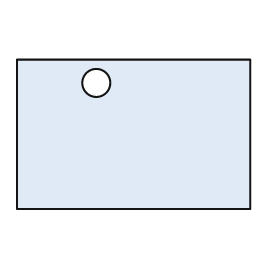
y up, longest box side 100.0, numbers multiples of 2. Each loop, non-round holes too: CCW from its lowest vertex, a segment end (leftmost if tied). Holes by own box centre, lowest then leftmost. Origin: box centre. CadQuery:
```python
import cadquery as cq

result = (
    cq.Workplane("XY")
    .moveTo(-50.0, -32.0)
    .lineTo(50.0, -32.0)
    .lineTo(50.0, 32.0)
    .lineTo(-50.0, 32.0)
    .close()
    .moveTo(-16.0, 22.0)
    .circle(6.0)
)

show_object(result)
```